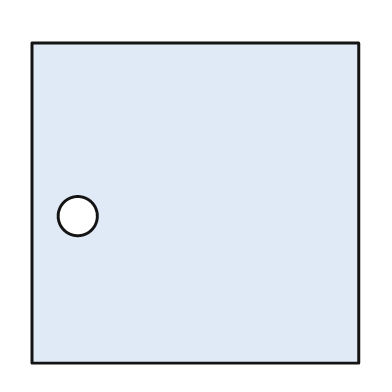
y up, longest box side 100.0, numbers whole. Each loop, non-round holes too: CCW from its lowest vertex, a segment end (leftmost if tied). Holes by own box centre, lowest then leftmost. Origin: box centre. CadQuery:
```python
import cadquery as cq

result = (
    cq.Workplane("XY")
    .moveTo(-50.0, -49.0)
    .lineTo(50.0, -49.0)
    .lineTo(50.0, 49.0)
    .lineTo(-50.0, 49.0)
    .close()
    .moveTo(-36.0, -4.0)
    .circle(6.0)
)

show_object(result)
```